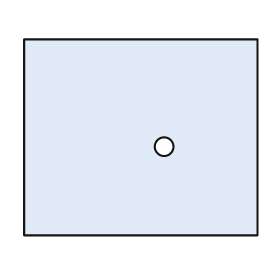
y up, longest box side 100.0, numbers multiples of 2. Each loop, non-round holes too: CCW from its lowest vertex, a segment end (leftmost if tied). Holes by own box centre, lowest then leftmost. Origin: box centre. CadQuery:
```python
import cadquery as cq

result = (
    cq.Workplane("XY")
    .moveTo(-50.0, -42.0)
    .lineTo(50.0, -42.0)
    .lineTo(50.0, 42.0)
    .lineTo(-50.0, 42.0)
    .close()
    .moveTo(10.0, -4.0)
    .circle(4.0)
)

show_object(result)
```